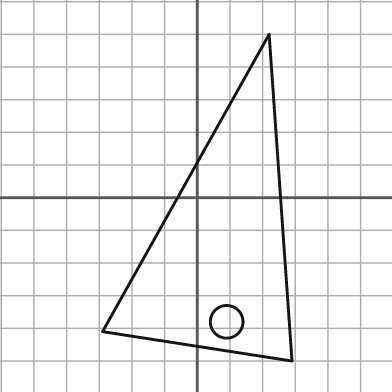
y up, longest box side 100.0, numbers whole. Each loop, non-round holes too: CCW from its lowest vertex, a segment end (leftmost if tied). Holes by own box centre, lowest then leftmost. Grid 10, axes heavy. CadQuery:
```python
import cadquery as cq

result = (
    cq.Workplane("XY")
    .moveTo(29.0, -50.0)
    .lineTo(22.0, 50.0)
    .lineTo(-29.0, -41.0)
    .close()
    .moveTo(9.0, -38.0)
    .circle(5.0)
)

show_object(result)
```